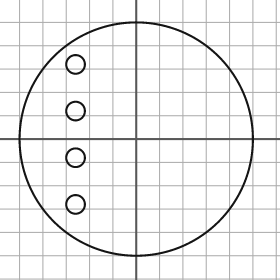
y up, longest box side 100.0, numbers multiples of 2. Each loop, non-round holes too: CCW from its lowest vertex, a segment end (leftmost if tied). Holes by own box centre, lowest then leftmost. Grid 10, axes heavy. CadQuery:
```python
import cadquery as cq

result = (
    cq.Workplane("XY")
    .moveTo(0.0, 0.0)
    .circle(50.0)
    .moveTo(-26.0, -28.0)
    .circle(4.0)
    .moveTo(-26.0, -8.0)
    .circle(4.0)
    .moveTo(-26.0, 12.0)
    .circle(4.0)
    .moveTo(-26.0, 32.0)
    .circle(4.0)
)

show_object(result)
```